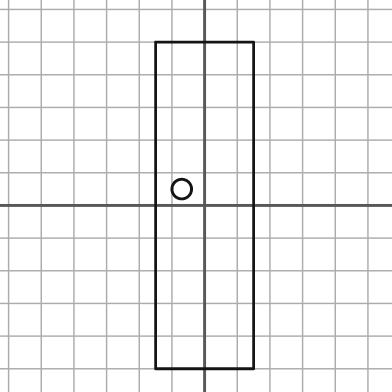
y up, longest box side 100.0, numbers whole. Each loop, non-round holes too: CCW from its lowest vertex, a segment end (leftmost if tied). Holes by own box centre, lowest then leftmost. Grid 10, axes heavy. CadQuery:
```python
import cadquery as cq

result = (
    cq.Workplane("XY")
    .moveTo(-15.0, -50.0)
    .lineTo(15.0, -50.0)
    .lineTo(15.0, 50.0)
    .lineTo(-15.0, 50.0)
    .close()
    .moveTo(-7.0, 5.0)
    .circle(3.0)
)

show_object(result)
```